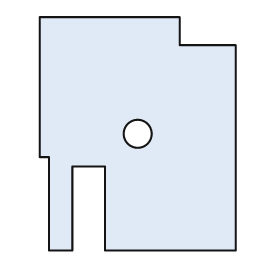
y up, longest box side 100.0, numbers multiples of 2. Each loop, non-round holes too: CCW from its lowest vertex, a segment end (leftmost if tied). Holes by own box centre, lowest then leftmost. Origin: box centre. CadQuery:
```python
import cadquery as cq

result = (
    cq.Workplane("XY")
    .moveTo(-38.0, -50.0)
    .lineTo(-28.0, -50.0)
    .lineTo(-28.0, -14.0)
    .lineTo(-14.0, -14.0)
    .lineTo(-14.0, -50.0)
    .lineTo(42.0, -50.0)
    .lineTo(42.0, 38.0)
    .lineTo(18.0, 38.0)
    .lineTo(18.0, 50.0)
    .lineTo(-42.0, 50.0)
    .lineTo(-42.0, -10.0)
    .lineTo(-38.0, -10.0)
    .close()
    .moveTo(0.0, 0.0)
    .circle(6.0)
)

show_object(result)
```